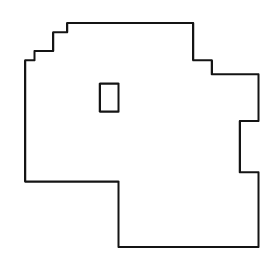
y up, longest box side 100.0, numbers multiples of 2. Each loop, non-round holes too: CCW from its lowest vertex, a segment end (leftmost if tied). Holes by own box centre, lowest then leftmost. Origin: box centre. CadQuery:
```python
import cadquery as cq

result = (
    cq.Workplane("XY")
    .moveTo(-10.0, -48.0)
    .lineTo(50.0, -48.0)
    .lineTo(50.0, -16.0)
    .lineTo(42.0, -16.0)
    .lineTo(42.0, 6.0)
    .lineTo(50.0, 6.0)
    .lineTo(50.0, 26.0)
    .lineTo(30.0, 26.0)
    .lineTo(30.0, 32.0)
    .lineTo(22.0, 32.0)
    .lineTo(22.0, 48.0)
    .lineTo(-32.0, 48.0)
    .lineTo(-32.0, 44.0)
    .lineTo(-38.0, 44.0)
    .lineTo(-38.0, 36.0)
    .lineTo(-46.0, 36.0)
    .lineTo(-46.0, 32.0)
    .lineTo(-50.0, 32.0)
    .lineTo(-50.0, -20.0)
    .lineTo(-10.0, -20.0)
    .close()
    .moveTo(-18.0, 10.0)
    .lineTo(-10.0, 10.0)
    .lineTo(-10.0, 22.0)
    .lineTo(-18.0, 22.0)
    .close()
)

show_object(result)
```